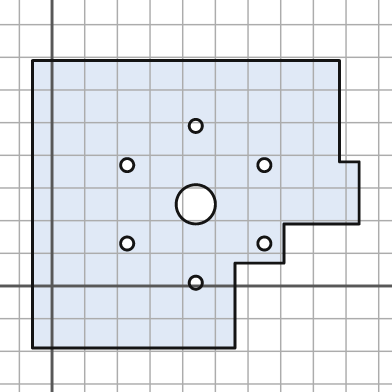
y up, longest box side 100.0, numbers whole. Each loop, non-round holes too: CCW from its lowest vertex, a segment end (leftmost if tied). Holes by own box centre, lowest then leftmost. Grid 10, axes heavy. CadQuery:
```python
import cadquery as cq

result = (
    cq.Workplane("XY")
    .moveTo(-6.0, -19.0)
    .lineTo(56.0, -19.0)
    .lineTo(56.0, 7.0)
    .lineTo(71.0, 7.0)
    .lineTo(71.0, 19.0)
    .lineTo(94.0, 19.0)
    .lineTo(94.0, 38.0)
    .lineTo(88.0, 38.0)
    .lineTo(88.0, 69.0)
    .lineTo(-6.0, 69.0)
    .close()
    .moveTo(44.0, 1.0)
    .circle(2.0)
    .moveTo(23.0, 13.0)
    .circle(2.0)
    .moveTo(65.0, 13.0)
    .circle(2.0)
    .moveTo(44.0, 25.0)
    .circle(6.0)
    .moveTo(23.0, 37.0)
    .circle(2.0)
    .moveTo(65.0, 37.0)
    .circle(2.0)
    .moveTo(44.0, 49.0)
    .circle(2.0)
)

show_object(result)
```